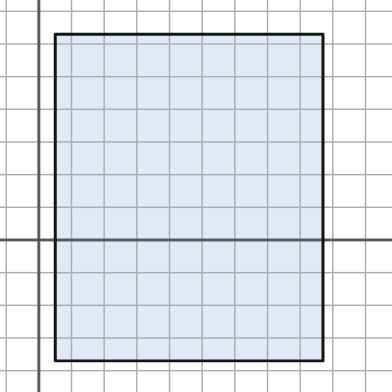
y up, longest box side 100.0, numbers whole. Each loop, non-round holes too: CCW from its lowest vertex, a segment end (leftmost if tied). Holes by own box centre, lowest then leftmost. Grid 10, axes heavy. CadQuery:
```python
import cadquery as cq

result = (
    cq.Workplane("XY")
    .moveTo(5.0, -37.0)
    .lineTo(87.0, -37.0)
    .lineTo(87.0, 63.0)
    .lineTo(5.0, 63.0)
    .close()
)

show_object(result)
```